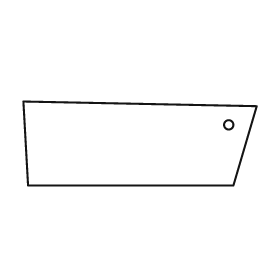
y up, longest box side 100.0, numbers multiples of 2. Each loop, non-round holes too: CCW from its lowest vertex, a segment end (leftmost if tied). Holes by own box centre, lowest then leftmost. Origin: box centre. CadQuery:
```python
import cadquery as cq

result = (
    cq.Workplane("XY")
    .moveTo(-48.0, -18.0)
    .lineTo(40.0, -18.0)
    .lineTo(50.0, 16.0)
    .lineTo(-50.0, 18.0)
    .close()
    .moveTo(38.0, 8.0)
    .circle(2.0)
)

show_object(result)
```